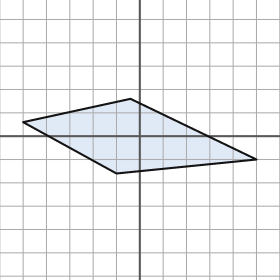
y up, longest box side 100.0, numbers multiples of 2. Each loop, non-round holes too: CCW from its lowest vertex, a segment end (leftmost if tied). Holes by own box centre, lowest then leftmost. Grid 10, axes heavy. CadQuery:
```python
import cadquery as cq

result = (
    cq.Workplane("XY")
    .moveTo(-10.0, -16.0)
    .lineTo(50.0, -10.0)
    .lineTo(-4.0, 16.0)
    .lineTo(-50.0, 6.0)
    .close()
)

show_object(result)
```